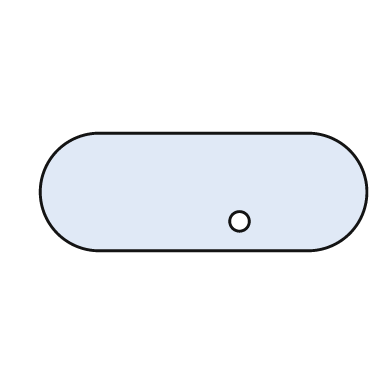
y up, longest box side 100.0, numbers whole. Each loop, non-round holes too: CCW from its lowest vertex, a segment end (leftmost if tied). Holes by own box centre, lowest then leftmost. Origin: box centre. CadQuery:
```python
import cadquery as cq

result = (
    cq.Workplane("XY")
    .moveTo(-32.0, -18.0)
    .lineTo(32.0, -18.0)
    .threePointArc((50.0, 0.0), (32.0, 18.0))
    .lineTo(-32.0, 18.0)
    .threePointArc((-50.0, 0.0), (-32.0, -18.0))
    .close()
    .moveTo(11.0, -9.0)
    .circle(3.0)
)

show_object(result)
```